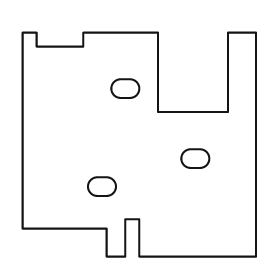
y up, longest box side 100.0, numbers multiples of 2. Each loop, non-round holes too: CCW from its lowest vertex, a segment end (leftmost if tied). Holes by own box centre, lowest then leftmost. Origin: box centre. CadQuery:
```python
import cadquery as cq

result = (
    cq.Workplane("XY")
    .moveTo(-14.0, -48.0)
    .lineTo(-6.0, -48.0)
    .lineTo(-6.0, -32.0)
    .lineTo(0.0, -32.0)
    .lineTo(0.0, -48.0)
    .lineTo(50.0, -48.0)
    .lineTo(50.0, 48.0)
    .lineTo(38.0, 48.0)
    .lineTo(38.0, 14.0)
    .lineTo(8.0, 14.0)
    .lineTo(8.0, 48.0)
    .lineTo(-24.0, 48.0)
    .lineTo(-24.0, 42.0)
    .lineTo(-44.0, 42.0)
    .lineTo(-44.0, 48.0)
    .lineTo(-50.0, 48.0)
    .lineTo(-50.0, -36.0)
    .lineTo(-14.0, -36.0)
    .close()
    .moveTo(-18.0, -22.0)
    .lineTo(-14.0, -22.0)
    .threePointArc((-10.0, -18.0), (-14.0, -14.0))
    .lineTo(-18.0, -14.0)
    .threePointArc((-22.0, -18.0), (-18.0, -22.0))
    .close()
    .moveTo(22.0, -10.0)
    .lineTo(26.0, -10.0)
    .threePointArc((30.0, -6.0), (26.0, -2.0))
    .lineTo(22.0, -2.0)
    .threePointArc((18.0, -6.0), (22.0, -10.0))
    .close()
    .moveTo(-8.0, 20.0)
    .lineTo(-4.0, 20.0)
    .threePointArc((0.0, 24.0), (-4.0, 28.0))
    .lineTo(-8.0, 28.0)
    .threePointArc((-12.0, 24.0), (-8.0, 20.0))
    .close()
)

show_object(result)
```